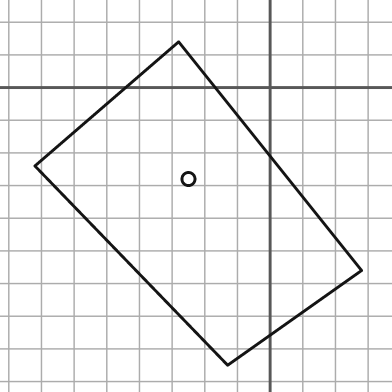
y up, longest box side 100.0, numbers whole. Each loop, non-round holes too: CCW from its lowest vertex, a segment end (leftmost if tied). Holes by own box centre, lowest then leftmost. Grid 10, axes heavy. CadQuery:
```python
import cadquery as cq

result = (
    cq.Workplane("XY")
    .moveTo(-13.0, -85.0)
    .lineTo(28.0, -56.0)
    .lineTo(-28.0, 14.0)
    .lineTo(-72.0, -24.0)
    .close()
    .moveTo(-25.0, -28.0)
    .circle(2.0)
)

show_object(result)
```